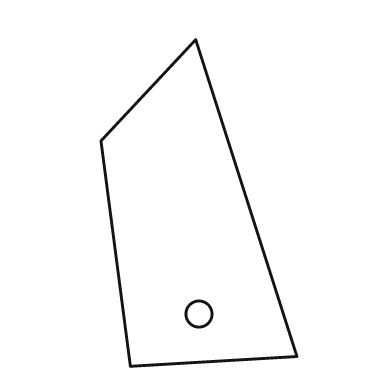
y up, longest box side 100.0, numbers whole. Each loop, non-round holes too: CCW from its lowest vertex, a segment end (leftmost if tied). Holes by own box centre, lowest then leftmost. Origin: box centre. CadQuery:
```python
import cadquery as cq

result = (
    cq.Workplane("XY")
    .moveTo(-21.0, -50.0)
    .lineTo(30.0, -47.0)
    .lineTo(-1.0, 50.0)
    .lineTo(-30.0, 19.0)
    .close()
    .moveTo(0.0, -34.0)
    .circle(4.0)
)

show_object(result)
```